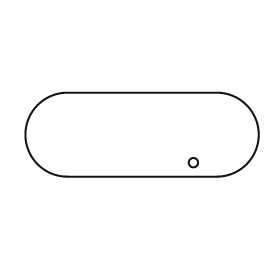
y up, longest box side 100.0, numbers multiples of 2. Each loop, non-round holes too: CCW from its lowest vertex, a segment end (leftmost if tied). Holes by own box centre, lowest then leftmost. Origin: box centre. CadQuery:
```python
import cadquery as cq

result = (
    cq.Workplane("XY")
    .moveTo(-32.0, -18.0)
    .lineTo(32.0, -18.0)
    .threePointArc((50.0, 0.0), (32.0, 18.0))
    .lineTo(-32.0, 18.0)
    .threePointArc((-50.0, 0.0), (-32.0, -18.0))
    .close()
    .moveTo(22.0, -12.0)
    .circle(2.0)
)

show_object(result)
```